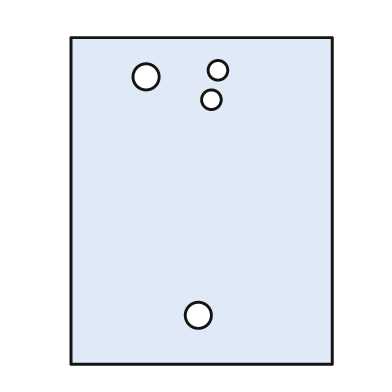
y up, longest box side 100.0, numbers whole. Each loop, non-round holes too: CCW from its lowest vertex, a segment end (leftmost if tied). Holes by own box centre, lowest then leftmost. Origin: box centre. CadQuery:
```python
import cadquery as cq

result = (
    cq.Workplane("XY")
    .moveTo(-40.0, -50.0)
    .lineTo(40.0, -50.0)
    .lineTo(40.0, 50.0)
    .lineTo(-40.0, 50.0)
    .close()
    .moveTo(-1.0, -35.0)
    .circle(4.0)
    .moveTo(3.0, 31.0)
    .circle(3.0)
    .moveTo(-17.0, 38.0)
    .circle(4.0)
    .moveTo(5.0, 40.0)
    .circle(3.0)
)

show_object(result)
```